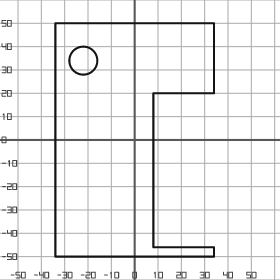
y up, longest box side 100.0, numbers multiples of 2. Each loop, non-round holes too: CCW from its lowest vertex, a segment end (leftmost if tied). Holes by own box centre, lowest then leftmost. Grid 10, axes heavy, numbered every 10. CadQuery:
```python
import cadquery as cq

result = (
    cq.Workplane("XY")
    .moveTo(-34.0, -50.0)
    .lineTo(34.0, -50.0)
    .lineTo(34.0, -46.0)
    .lineTo(8.0, -46.0)
    .lineTo(8.0, 20.0)
    .lineTo(34.0, 20.0)
    .lineTo(34.0, 50.0)
    .lineTo(-34.0, 50.0)
    .close()
    .moveTo(-22.0, 34.0)
    .circle(6.0)
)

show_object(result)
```